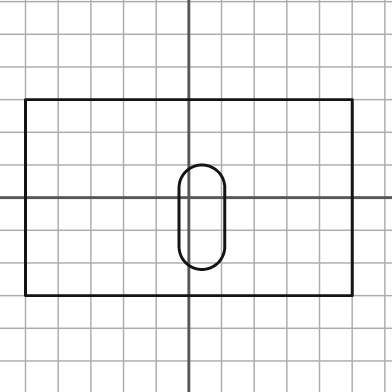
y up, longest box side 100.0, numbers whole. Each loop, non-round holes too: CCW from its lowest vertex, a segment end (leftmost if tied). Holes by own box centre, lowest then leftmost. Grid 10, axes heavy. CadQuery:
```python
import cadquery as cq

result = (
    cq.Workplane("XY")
    .moveTo(-50.0, -30.0)
    .lineTo(50.0, -30.0)
    .lineTo(50.0, 30.0)
    .lineTo(-50.0, 30.0)
    .close()
    .moveTo(-3.0, -15.0)
    .threePointArc((4.0, -22.0), (11.0, -15.0))
    .lineTo(11.0, 3.0)
    .threePointArc((4.0, 10.0), (-3.0, 3.0))
    .close()
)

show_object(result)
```